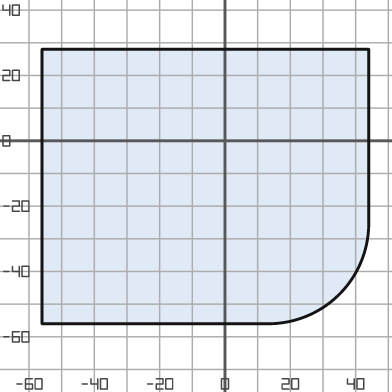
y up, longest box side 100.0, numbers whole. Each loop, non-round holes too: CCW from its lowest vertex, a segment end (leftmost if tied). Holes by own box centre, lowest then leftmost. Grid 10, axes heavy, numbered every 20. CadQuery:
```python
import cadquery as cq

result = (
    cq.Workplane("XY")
    .moveTo(-56.0, -56.0)
    .lineTo(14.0, -56.0)
    .threePointArc((35.0, -47.0), (44.0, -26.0))
    .lineTo(44.0, 28.0)
    .lineTo(-56.0, 28.0)
    .close()
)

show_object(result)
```